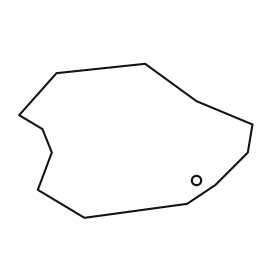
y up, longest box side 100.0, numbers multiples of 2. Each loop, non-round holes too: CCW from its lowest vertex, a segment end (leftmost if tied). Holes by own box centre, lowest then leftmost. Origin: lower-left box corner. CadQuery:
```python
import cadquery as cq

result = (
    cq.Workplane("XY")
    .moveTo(28.0, 0.0)
    .lineTo(72.0, 6.0)
    .lineTo(84.0, 14.0)
    .lineTo(98.0, 28.0)
    .lineTo(100.0, 40.0)
    .lineTo(76.0, 50.0)
    .lineTo(54.0, 66.0)
    .lineTo(16.0, 62.0)
    .lineTo(0.0, 44.0)
    .lineTo(10.0, 38.0)
    .lineTo(14.0, 28.0)
    .lineTo(8.0, 12.0)
    .close()
    .moveTo(76.0, 16.0)
    .circle(2.0)
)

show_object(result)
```